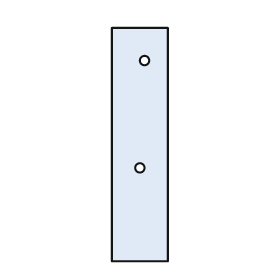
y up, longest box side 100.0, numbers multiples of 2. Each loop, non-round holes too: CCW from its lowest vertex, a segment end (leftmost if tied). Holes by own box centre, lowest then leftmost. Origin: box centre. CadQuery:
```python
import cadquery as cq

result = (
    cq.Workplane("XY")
    .moveTo(-12.0, -50.0)
    .lineTo(12.0, -50.0)
    .lineTo(12.0, 50.0)
    .lineTo(-12.0, 50.0)
    .close()
    .moveTo(0.0, -10.0)
    .circle(2.0)
    .moveTo(2.0, 36.0)
    .circle(2.0)
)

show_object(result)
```